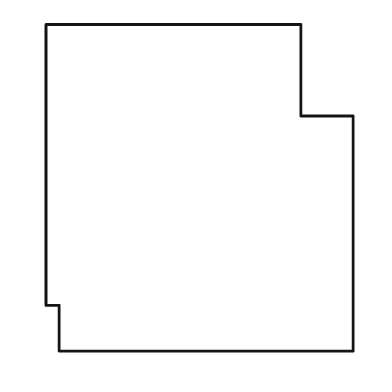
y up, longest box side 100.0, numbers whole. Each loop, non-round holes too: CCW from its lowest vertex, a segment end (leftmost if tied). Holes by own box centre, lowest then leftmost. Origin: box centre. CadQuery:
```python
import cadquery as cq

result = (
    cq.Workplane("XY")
    .moveTo(-43.0, -50.0)
    .lineTo(47.0, -50.0)
    .lineTo(47.0, 22.0)
    .lineTo(31.0, 22.0)
    .lineTo(31.0, 50.0)
    .lineTo(-47.0, 50.0)
    .lineTo(-47.0, -36.0)
    .lineTo(-43.0, -36.0)
    .close()
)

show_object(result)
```